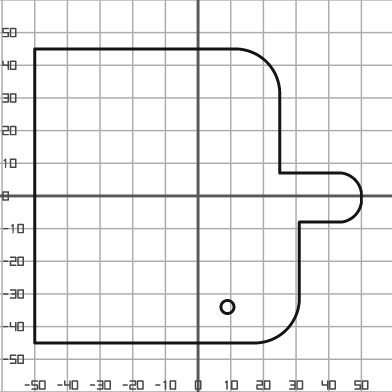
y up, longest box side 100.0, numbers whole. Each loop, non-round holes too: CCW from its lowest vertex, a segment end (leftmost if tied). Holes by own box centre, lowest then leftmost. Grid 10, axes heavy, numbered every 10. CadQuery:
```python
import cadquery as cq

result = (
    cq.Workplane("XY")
    .moveTo(-50.0, -45.0)
    .lineTo(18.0, -45.0)
    .threePointArc((27.0, -41.0), (31.0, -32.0))
    .lineTo(31.0, -8.0)
    .lineTo(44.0, -8.0)
    .threePointArc((48.0, -6.0), (50.0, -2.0))
    .lineTo(50.0, 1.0)
    .threePointArc((48.0, 5.0), (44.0, 7.0))
    .lineTo(25.0, 7.0)
    .lineTo(25.0, 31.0)
    .threePointArc((21.0, 41.0), (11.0, 45.0))
    .lineTo(-50.0, 45.0)
    .close()
    .moveTo(9.0, -34.0)
    .circle(2.0)
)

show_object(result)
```